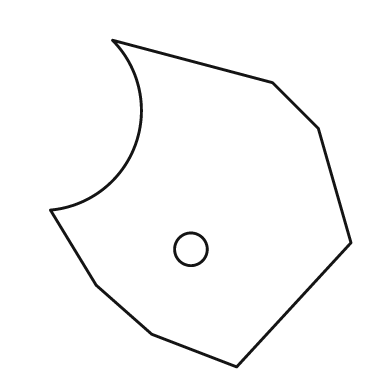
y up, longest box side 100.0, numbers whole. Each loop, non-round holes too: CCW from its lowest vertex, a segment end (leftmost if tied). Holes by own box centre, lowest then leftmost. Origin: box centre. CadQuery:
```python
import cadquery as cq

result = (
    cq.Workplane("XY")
    .moveTo(11.0, -50.0)
    .lineTo(46.0, -12.0)
    .lineTo(36.0, 23.0)
    .lineTo(22.0, 37.0)
    .lineTo(-27.0, 50.0)
    .threePointArc((-20.0, 18.0), (-46.0, -2.0))
    .lineTo(-32.0, -25.0)
    .lineTo(-15.0, -40.0)
    .close()
    .moveTo(-3.0, -14.0)
    .circle(5.0)
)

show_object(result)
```